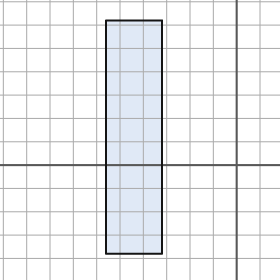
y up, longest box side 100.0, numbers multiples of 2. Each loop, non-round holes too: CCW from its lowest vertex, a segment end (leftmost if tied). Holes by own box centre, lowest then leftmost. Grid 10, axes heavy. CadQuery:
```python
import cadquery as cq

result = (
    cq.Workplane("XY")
    .moveTo(-56.0, -38.0)
    .lineTo(-32.0, -38.0)
    .lineTo(-32.0, 62.0)
    .lineTo(-56.0, 62.0)
    .close()
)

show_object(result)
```